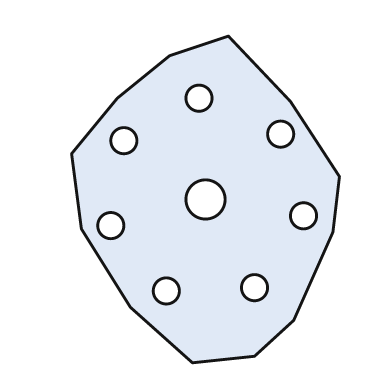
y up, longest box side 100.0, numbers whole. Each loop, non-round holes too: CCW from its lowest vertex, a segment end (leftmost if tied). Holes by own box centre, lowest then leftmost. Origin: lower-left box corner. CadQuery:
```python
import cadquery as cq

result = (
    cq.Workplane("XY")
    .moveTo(37.0, 0.0)
    .lineTo(56.0, 2.0)
    .lineTo(68.0, 13.0)
    .lineTo(80.0, 40.0)
    .lineTo(82.0, 57.0)
    .lineTo(67.0, 80.0)
    .lineTo(48.0, 100.0)
    .lineTo(30.0, 94.0)
    .lineTo(14.0, 81.0)
    .lineTo(0.0, 64.0)
    .lineTo(3.0, 41.0)
    .lineTo(18.0, 17.0)
    .close()
    .moveTo(29.0, 22.0)
    .circle(4.0)
    .moveTo(56.0, 23.0)
    .circle(4.0)
    .moveTo(12.0, 42.0)
    .circle(4.0)
    .moveTo(71.0, 45.0)
    .circle(4.0)
    .moveTo(41.0, 50.0)
    .circle(6.0)
    .moveTo(16.0, 68.0)
    .circle(4.0)
    .moveTo(64.0, 70.0)
    .circle(4.0)
    .moveTo(39.0, 81.0)
    .circle(4.0)
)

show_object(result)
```